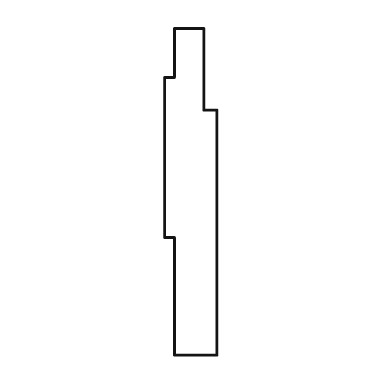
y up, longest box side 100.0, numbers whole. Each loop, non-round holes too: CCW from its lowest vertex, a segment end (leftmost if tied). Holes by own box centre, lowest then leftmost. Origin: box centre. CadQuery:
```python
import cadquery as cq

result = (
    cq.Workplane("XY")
    .moveTo(-5.0, -50.0)
    .lineTo(8.0, -50.0)
    .lineTo(8.0, 25.0)
    .lineTo(4.0, 25.0)
    .lineTo(4.0, 50.0)
    .lineTo(-5.0, 50.0)
    .lineTo(-5.0, 35.0)
    .lineTo(-8.0, 35.0)
    .lineTo(-8.0, -14.0)
    .lineTo(-5.0, -14.0)
    .close()
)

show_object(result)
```